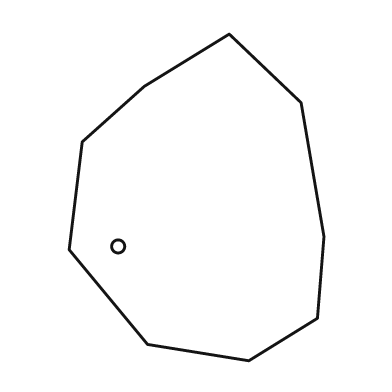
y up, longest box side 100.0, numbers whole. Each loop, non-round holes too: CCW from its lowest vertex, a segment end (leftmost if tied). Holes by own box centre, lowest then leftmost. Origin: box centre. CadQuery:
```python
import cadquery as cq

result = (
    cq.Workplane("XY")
    .moveTo(16.0, -50.0)
    .lineTo(37.0, -37.0)
    .lineTo(39.0, -12.0)
    .lineTo(32.0, 29.0)
    .lineTo(10.0, 50.0)
    .lineTo(-16.0, 34.0)
    .lineTo(-35.0, 17.0)
    .lineTo(-39.0, -16.0)
    .lineTo(-15.0, -45.0)
    .close()
    .moveTo(-24.0, -15.0)
    .circle(2.0)
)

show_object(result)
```